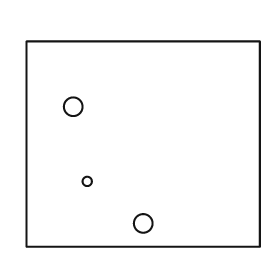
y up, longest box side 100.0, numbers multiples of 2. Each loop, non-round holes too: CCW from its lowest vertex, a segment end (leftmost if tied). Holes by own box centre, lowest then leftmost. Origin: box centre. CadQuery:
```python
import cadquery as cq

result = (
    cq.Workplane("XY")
    .moveTo(-50.0, -44.0)
    .lineTo(50.0, -44.0)
    .lineTo(50.0, 44.0)
    .lineTo(-50.0, 44.0)
    .close()
    .moveTo(0.0, -34.0)
    .circle(4.0)
    .moveTo(-24.0, -16.0)
    .circle(2.0)
    .moveTo(-30.0, 16.0)
    .circle(4.0)
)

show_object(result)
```